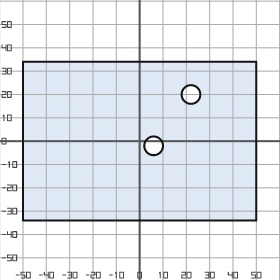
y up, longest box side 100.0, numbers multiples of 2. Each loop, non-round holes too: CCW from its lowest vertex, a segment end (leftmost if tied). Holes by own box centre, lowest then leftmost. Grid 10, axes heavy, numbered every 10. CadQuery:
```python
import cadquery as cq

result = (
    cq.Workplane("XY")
    .moveTo(-50.0, -34.0)
    .lineTo(50.0, -34.0)
    .lineTo(50.0, 34.0)
    .lineTo(-50.0, 34.0)
    .close()
    .moveTo(6.0, -2.0)
    .circle(4.0)
    .moveTo(22.0, 20.0)
    .circle(4.0)
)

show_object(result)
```